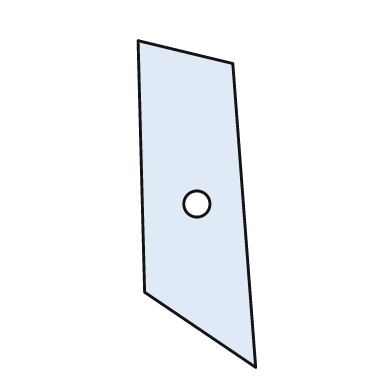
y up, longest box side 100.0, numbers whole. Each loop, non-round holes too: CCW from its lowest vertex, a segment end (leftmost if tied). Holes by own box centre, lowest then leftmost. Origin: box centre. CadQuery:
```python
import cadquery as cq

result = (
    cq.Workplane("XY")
    .moveTo(18.0, -50.0)
    .lineTo(11.0, 43.0)
    .lineTo(-18.0, 50.0)
    .lineTo(-16.0, -27.0)
    .close()
    .moveTo(0.0, 0.0)
    .circle(4.0)
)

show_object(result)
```